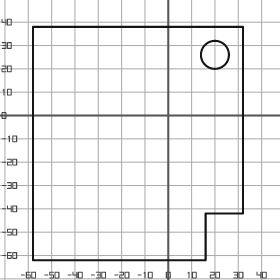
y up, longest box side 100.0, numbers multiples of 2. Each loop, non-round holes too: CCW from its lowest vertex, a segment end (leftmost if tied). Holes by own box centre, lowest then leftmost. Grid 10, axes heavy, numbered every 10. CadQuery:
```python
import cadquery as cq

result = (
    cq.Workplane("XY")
    .moveTo(-58.0, -62.0)
    .lineTo(16.0, -62.0)
    .lineTo(16.0, -42.0)
    .lineTo(32.0, -42.0)
    .lineTo(32.0, 38.0)
    .lineTo(-58.0, 38.0)
    .close()
    .moveTo(20.0, 26.0)
    .circle(6.0)
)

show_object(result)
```